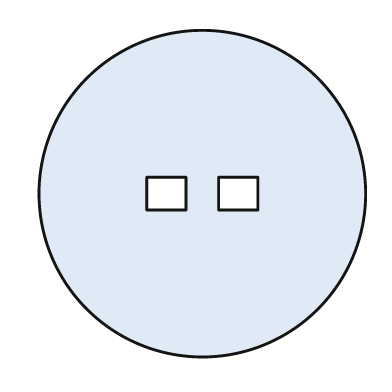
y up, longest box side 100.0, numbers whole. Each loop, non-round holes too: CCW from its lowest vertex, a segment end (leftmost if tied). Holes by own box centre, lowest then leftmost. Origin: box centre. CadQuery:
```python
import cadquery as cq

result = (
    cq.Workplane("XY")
    .moveTo(0.0, 0.0)
    .circle(50.0)
    .moveTo(-17.0, -5.0)
    .lineTo(-5.0, -5.0)
    .lineTo(-5.0, 5.0)
    .lineTo(-17.0, 5.0)
    .close()
    .moveTo(5.0, -5.0)
    .lineTo(17.0, -5.0)
    .lineTo(17.0, 5.0)
    .lineTo(5.0, 5.0)
    .close()
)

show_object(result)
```